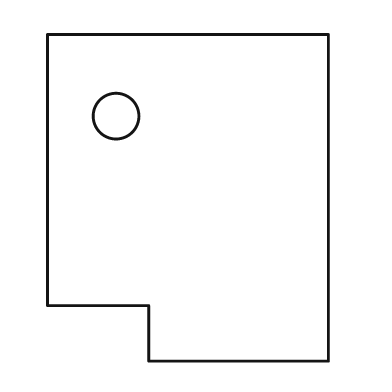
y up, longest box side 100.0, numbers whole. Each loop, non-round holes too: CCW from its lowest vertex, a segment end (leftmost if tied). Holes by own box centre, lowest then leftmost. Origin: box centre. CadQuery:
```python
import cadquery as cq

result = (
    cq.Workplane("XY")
    .moveTo(-12.0, -50.0)
    .lineTo(43.0, -50.0)
    .lineTo(43.0, 50.0)
    .lineTo(-43.0, 50.0)
    .lineTo(-43.0, -33.0)
    .lineTo(-12.0, -33.0)
    .close()
    .moveTo(-22.0, 25.0)
    .circle(7.0)
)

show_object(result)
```